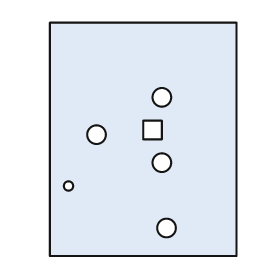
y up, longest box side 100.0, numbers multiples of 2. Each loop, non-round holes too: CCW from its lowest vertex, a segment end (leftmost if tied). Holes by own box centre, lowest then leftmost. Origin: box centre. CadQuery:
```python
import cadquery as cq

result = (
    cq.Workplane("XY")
    .moveTo(-40.0, -50.0)
    .lineTo(40.0, -50.0)
    .lineTo(40.0, 50.0)
    .lineTo(-40.0, 50.0)
    .close()
    .moveTo(10.0, -38.0)
    .circle(4.0)
    .moveTo(-32.0, -20.0)
    .circle(2.0)
    .moveTo(8.0, -10.0)
    .circle(4.0)
    .moveTo(-20.0, 2.0)
    .circle(4.0)
    .moveTo(0.0, 0.0)
    .lineTo(8.0, 0.0)
    .lineTo(8.0, 8.0)
    .lineTo(0.0, 8.0)
    .close()
    .moveTo(8.0, 18.0)
    .circle(4.0)
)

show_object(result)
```